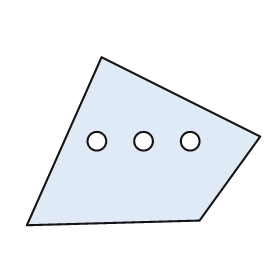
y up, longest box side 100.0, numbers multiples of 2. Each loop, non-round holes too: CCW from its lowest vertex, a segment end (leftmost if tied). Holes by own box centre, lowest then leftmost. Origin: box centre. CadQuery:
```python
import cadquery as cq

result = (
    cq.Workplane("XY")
    .moveTo(-50.0, -36.0)
    .lineTo(24.0, -34.0)
    .lineTo(50.0, 2.0)
    .lineTo(-18.0, 36.0)
    .close()
    .moveTo(-20.0, 0.0)
    .circle(4.0)
    .moveTo(0.0, 0.0)
    .circle(4.0)
    .moveTo(20.0, 0.0)
    .circle(4.0)
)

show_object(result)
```